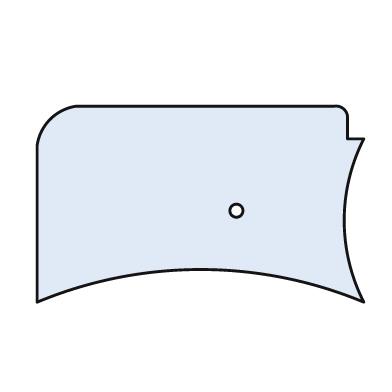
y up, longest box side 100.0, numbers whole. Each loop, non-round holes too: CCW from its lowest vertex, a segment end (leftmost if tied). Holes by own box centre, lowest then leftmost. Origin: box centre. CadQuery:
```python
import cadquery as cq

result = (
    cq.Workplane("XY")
    .moveTo(-50.0, -30.0)
    .threePointArc((0.0, -20.0), (50.0, -30.0))
    .threePointArc((44.0, -5.0), (50.0, 20.0))
    .lineTo(45.0, 20.0)
    .lineTo(45.0, 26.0)
    .threePointArc((44.0, 29.0), (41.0, 30.0))
    .lineTo(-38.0, 30.0)
    .threePointArc((-46.0, 26.0), (-50.0, 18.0))
    .close()
    .moveTo(11.0, -2.0)
    .circle(2.0)
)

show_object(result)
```